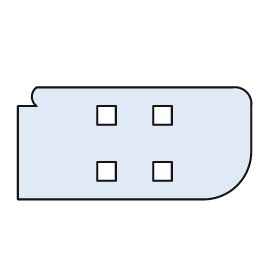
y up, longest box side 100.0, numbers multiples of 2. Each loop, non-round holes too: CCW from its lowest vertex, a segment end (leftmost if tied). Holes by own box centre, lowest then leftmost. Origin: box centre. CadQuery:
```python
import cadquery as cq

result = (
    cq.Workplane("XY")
    .moveTo(-50.0, -24.0)
    .lineTo(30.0, -24.0)
    .threePointArc((44.0, -18.0), (50.0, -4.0))
    .lineTo(50.0, 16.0)
    .threePointArc((48.0, 22.0), (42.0, 24.0))
    .lineTo(-42.0, 24.0)
    .threePointArc((-44.0, 20.0), (-42.0, 16.0))
    .lineTo(-50.0, 16.0)
    .close()
    .moveTo(-16.0, -16.0)
    .lineTo(-8.0, -16.0)
    .lineTo(-8.0, -8.0)
    .lineTo(-16.0, -8.0)
    .close()
    .moveTo(8.0, -16.0)
    .lineTo(16.0, -16.0)
    .lineTo(16.0, -8.0)
    .lineTo(8.0, -8.0)
    .close()
    .moveTo(-16.0, 8.0)
    .lineTo(-8.0, 8.0)
    .lineTo(-8.0, 16.0)
    .lineTo(-16.0, 16.0)
    .close()
    .moveTo(8.0, 8.0)
    .lineTo(16.0, 8.0)
    .lineTo(16.0, 16.0)
    .lineTo(8.0, 16.0)
    .close()
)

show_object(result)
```